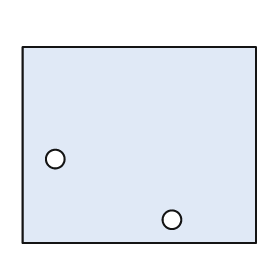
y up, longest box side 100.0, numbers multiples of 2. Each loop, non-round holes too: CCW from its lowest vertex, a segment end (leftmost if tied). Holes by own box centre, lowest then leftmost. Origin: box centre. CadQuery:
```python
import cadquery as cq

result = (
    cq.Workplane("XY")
    .moveTo(-50.0, -42.0)
    .lineTo(50.0, -42.0)
    .lineTo(50.0, 42.0)
    .lineTo(-50.0, 42.0)
    .close()
    .moveTo(14.0, -32.0)
    .circle(4.0)
    .moveTo(-36.0, -6.0)
    .circle(4.0)
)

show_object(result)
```